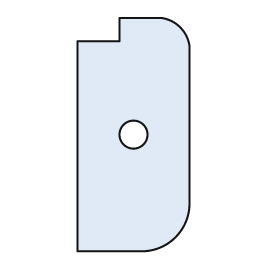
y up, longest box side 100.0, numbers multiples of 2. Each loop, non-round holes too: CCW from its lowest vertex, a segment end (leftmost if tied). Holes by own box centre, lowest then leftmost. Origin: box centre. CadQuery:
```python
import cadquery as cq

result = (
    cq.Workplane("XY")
    .moveTo(-24.0, -50.0)
    .lineTo(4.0, -50.0)
    .threePointArc((18.0, -44.0), (24.0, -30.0))
    .lineTo(24.0, 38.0)
    .threePointArc((20.0, 46.0), (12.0, 50.0))
    .lineTo(-6.0, 50.0)
    .lineTo(-6.0, 40.0)
    .lineTo(-24.0, 40.0)
    .close()
    .moveTo(0.0, 0.0)
    .circle(6.0)
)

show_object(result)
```